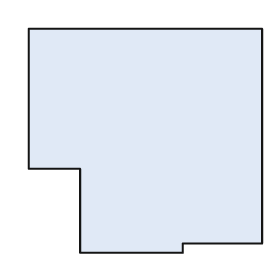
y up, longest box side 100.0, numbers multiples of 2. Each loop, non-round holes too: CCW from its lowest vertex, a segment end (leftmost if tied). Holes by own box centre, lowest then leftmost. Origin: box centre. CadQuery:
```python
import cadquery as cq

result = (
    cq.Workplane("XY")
    .moveTo(-28.0, -48.0)
    .lineTo(16.0, -48.0)
    .lineTo(16.0, -44.0)
    .lineTo(50.0, -44.0)
    .lineTo(50.0, 48.0)
    .lineTo(-50.0, 48.0)
    .lineTo(-50.0, -12.0)
    .lineTo(-28.0, -12.0)
    .close()
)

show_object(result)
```